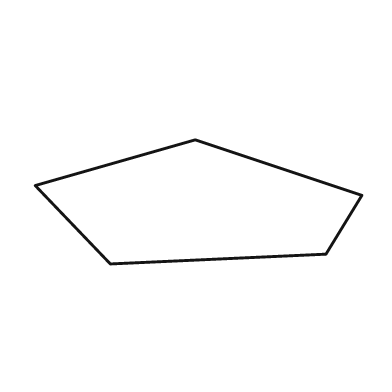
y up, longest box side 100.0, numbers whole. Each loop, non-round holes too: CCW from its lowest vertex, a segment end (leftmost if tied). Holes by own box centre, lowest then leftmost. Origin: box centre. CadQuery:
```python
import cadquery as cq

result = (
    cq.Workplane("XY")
    .moveTo(-27.0, -19.0)
    .lineTo(39.0, -16.0)
    .lineTo(50.0, 2.0)
    .lineTo(-1.0, 19.0)
    .lineTo(-50.0, 5.0)
    .close()
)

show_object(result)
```